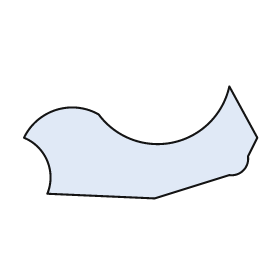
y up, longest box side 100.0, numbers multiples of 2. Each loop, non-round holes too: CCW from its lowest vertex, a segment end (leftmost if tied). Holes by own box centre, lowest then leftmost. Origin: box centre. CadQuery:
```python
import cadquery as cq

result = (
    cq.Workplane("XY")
    .moveTo(6.0, -24.0)
    .lineTo(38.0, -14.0)
    .threePointArc((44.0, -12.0), (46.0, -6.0))
    .lineTo(50.0, 2.0)
    .lineTo(38.0, 24.0)
    .threePointArc((14.0, 0.0), (-18.0, 12.0))
    .threePointArc((-36.0, 14.0), (-50.0, 2.0))
    .threePointArc((-40.0, -8.0), (-40.0, -22.0))
    .close()
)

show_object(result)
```